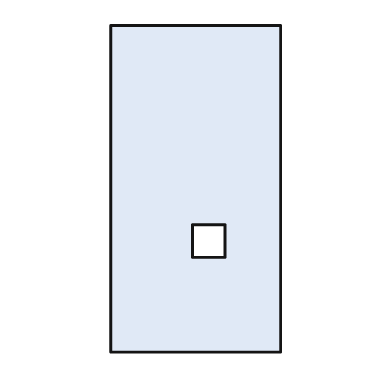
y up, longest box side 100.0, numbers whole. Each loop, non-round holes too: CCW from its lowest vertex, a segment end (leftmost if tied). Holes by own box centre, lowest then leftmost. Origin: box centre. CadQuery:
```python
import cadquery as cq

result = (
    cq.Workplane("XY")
    .moveTo(-26.0, -50.0)
    .lineTo(26.0, -50.0)
    .lineTo(26.0, 50.0)
    .lineTo(-26.0, 50.0)
    .close()
    .moveTo(-1.0, -21.0)
    .lineTo(9.0, -21.0)
    .lineTo(9.0, -11.0)
    .lineTo(-1.0, -11.0)
    .close()
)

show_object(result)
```